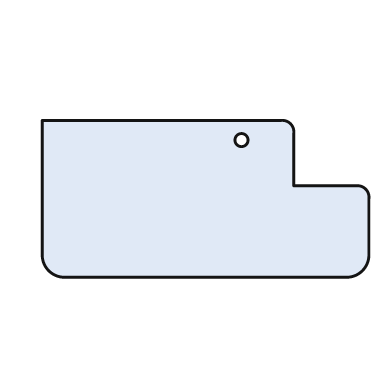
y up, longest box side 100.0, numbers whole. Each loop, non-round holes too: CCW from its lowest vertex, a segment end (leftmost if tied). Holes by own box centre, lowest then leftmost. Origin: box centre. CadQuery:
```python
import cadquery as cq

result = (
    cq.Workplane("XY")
    .moveTo(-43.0, -24.0)
    .lineTo(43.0, -24.0)
    .threePointArc((48.0, -22.0), (50.0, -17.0))
    .lineTo(50.0, 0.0)
    .threePointArc((49.0, 3.0), (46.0, 4.0))
    .lineTo(27.0, 4.0)
    .lineTo(27.0, 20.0)
    .threePointArc((26.0, 23.0), (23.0, 24.0))
    .lineTo(-50.0, 24.0)
    .lineTo(-50.0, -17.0)
    .threePointArc((-48.0, -22.0), (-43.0, -24.0))
    .close()
    .moveTo(11.0, 18.0)
    .circle(2.0)
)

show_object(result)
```